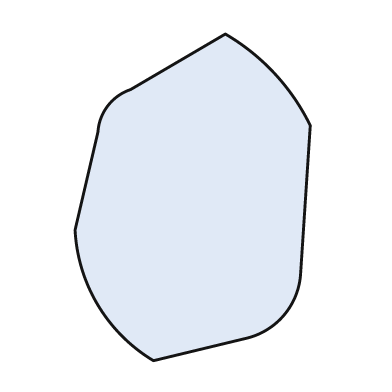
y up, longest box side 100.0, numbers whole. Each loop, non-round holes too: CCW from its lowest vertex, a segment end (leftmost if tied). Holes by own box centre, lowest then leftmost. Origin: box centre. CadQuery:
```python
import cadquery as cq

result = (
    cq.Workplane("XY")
    .moveTo(-12.0, -50.0)
    .lineTo(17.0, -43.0)
    .threePointArc((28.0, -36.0), (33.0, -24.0))
    .lineTo(36.0, 22.0)
    .threePointArc((25.0, 38.0), (10.0, 50.0))
    .lineTo(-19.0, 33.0)
    .threePointArc((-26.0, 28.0), (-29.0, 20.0))
    .lineTo(-36.0, -10.0)
    .threePointArc((-29.0, -33.0), (-12.0, -50.0))
    .close()
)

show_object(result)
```